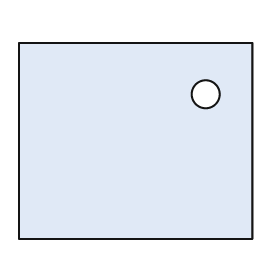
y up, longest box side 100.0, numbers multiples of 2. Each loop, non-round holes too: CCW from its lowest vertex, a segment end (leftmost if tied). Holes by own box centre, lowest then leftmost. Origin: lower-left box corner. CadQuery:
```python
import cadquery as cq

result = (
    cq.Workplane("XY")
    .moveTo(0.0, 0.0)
    .lineTo(100.0, 0.0)
    .lineTo(100.0, 84.0)
    .lineTo(0.0, 84.0)
    .close()
    .moveTo(80.0, 62.0)
    .circle(6.0)
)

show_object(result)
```